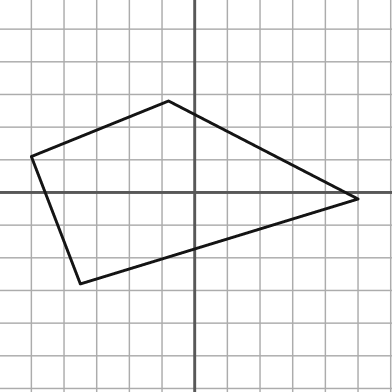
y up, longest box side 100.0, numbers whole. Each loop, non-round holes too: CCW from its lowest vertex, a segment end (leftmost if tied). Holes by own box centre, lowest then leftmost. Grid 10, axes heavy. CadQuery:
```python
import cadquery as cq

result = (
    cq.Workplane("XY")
    .moveTo(-35.0, -28.0)
    .lineTo(50.0, -2.0)
    .lineTo(-8.0, 28.0)
    .lineTo(-50.0, 11.0)
    .close()
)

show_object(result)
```